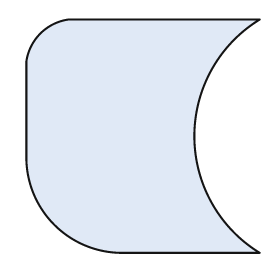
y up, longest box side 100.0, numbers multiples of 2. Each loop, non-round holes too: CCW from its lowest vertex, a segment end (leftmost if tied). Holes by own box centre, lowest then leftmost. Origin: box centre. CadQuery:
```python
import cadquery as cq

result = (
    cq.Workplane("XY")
    .moveTo(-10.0, -50.0)
    .lineTo(50.0, -50.0)
    .threePointArc((22.0, 0.0), (50.0, 50.0))
    .lineTo(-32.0, 50.0)
    .threePointArc((-44.0, 44.0), (-50.0, 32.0))
    .lineTo(-50.0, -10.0)
    .threePointArc((-38.0, -38.0), (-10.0, -50.0))
    .close()
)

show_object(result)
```